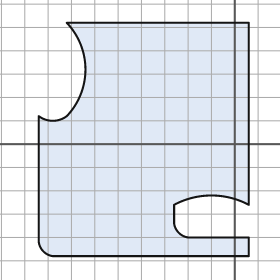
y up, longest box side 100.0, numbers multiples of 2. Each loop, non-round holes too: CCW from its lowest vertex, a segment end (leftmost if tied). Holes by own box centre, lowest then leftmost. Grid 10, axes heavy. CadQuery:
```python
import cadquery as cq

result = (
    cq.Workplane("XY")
    .moveTo(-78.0, -48.0)
    .lineTo(6.0, -48.0)
    .lineTo(6.0, -40.0)
    .lineTo(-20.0, -40.0)
    .threePointArc((-24.0, -38.0), (-26.0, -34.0))
    .lineTo(-26.0, -26.0)
    .threePointArc((-10.0, -22.0), (6.0, -26.0))
    .lineTo(6.0, 52.0)
    .lineTo(-72.0, 52.0)
    .threePointArc((-64.0, 32.0), (-72.0, 12.0))
    .threePointArc((-78.0, 10.0), (-84.0, 12.0))
    .lineTo(-84.0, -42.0)
    .threePointArc((-82.0, -46.0), (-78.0, -48.0))
    .close()
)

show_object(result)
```